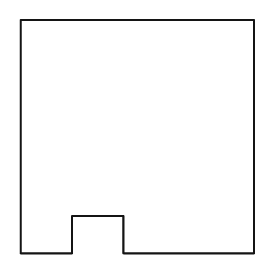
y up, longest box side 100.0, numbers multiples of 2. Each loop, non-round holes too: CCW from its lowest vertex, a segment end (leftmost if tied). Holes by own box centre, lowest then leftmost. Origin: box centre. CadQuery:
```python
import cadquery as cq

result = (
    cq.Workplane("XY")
    .moveTo(-50.0, -50.0)
    .lineTo(-28.0, -50.0)
    .lineTo(-28.0, -34.0)
    .lineTo(-6.0, -34.0)
    .lineTo(-6.0, -50.0)
    .lineTo(50.0, -50.0)
    .lineTo(50.0, 50.0)
    .lineTo(-50.0, 50.0)
    .close()
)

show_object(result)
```